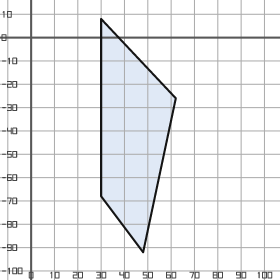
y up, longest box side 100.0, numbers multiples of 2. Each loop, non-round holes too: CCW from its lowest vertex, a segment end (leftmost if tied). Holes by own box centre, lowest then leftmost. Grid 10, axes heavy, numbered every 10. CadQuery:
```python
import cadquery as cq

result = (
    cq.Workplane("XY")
    .moveTo(48.0, -92.0)
    .lineTo(62.0, -26.0)
    .lineTo(30.0, 8.0)
    .lineTo(30.0, -68.0)
    .close()
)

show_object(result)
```